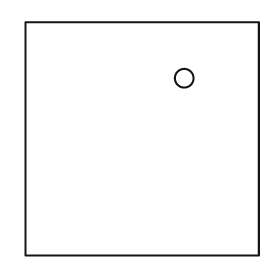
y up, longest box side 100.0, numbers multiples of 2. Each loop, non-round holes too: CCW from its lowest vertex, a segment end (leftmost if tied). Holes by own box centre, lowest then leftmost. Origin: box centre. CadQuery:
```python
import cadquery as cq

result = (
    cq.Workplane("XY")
    .moveTo(-50.0, -50.0)
    .lineTo(50.0, -50.0)
    .lineTo(50.0, 50.0)
    .lineTo(-50.0, 50.0)
    .close()
    .moveTo(18.0, 26.0)
    .circle(4.0)
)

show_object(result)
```